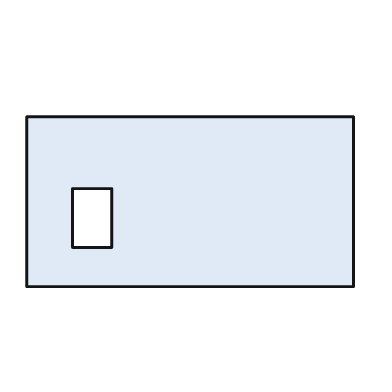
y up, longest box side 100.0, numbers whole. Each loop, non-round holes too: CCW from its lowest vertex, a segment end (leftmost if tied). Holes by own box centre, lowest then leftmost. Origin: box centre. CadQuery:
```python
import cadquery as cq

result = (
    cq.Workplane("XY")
    .moveTo(-50.0, -26.0)
    .lineTo(50.0, -26.0)
    .lineTo(50.0, 26.0)
    .lineTo(-50.0, 26.0)
    .close()
    .moveTo(-36.0, -14.0)
    .lineTo(-24.0, -14.0)
    .lineTo(-24.0, 4.0)
    .lineTo(-36.0, 4.0)
    .close()
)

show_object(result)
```